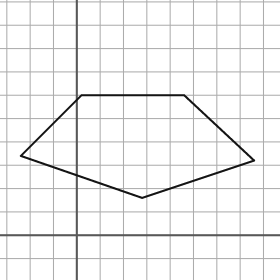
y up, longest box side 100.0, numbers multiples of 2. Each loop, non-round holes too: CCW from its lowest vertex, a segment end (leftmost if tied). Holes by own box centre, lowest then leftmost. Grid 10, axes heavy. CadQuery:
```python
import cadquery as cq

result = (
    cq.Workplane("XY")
    .moveTo(28.0, 16.0)
    .lineTo(76.0, 32.0)
    .lineTo(46.0, 60.0)
    .lineTo(2.0, 60.0)
    .lineTo(-24.0, 34.0)
    .close()
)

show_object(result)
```